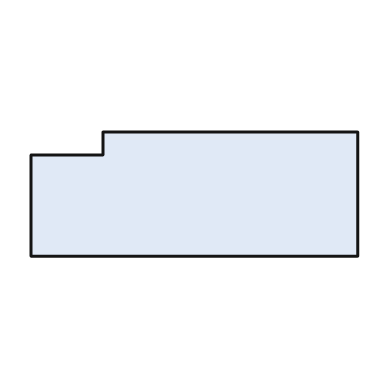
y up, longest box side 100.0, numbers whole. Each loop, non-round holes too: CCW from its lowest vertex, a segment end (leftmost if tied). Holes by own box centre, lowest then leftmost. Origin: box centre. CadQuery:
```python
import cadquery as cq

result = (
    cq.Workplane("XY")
    .moveTo(-50.0, -19.0)
    .lineTo(50.0, -19.0)
    .lineTo(50.0, 19.0)
    .lineTo(-28.0, 19.0)
    .lineTo(-28.0, 12.0)
    .lineTo(-50.0, 12.0)
    .close()
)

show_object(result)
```